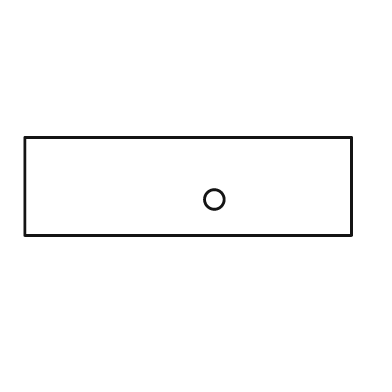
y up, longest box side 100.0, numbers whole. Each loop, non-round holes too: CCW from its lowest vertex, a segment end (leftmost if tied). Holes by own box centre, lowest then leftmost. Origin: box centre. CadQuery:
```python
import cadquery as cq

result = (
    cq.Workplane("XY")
    .moveTo(-50.0, -15.0)
    .lineTo(50.0, -15.0)
    .lineTo(50.0, 15.0)
    .lineTo(-50.0, 15.0)
    .close()
    .moveTo(8.0, -4.0)
    .circle(3.0)
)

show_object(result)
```